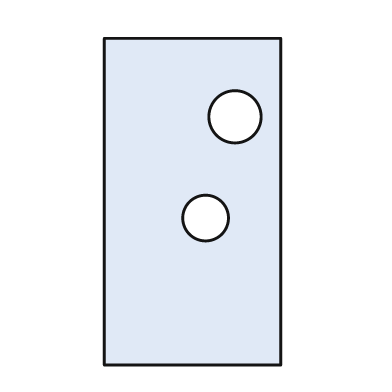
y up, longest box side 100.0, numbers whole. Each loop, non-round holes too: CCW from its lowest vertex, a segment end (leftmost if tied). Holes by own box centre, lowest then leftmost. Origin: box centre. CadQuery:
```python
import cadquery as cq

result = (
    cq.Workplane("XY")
    .moveTo(-27.0, -50.0)
    .lineTo(27.0, -50.0)
    .lineTo(27.0, 50.0)
    .lineTo(-27.0, 50.0)
    .close()
    .moveTo(4.0, -5.0)
    .circle(7.0)
    .moveTo(13.0, 26.0)
    .circle(8.0)
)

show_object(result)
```